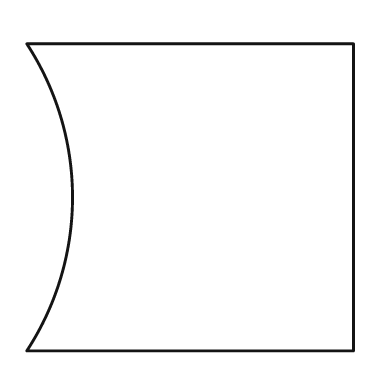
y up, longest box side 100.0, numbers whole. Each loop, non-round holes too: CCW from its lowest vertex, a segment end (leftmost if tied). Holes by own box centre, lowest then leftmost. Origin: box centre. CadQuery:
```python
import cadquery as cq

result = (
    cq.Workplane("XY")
    .moveTo(-50.0, -47.0)
    .lineTo(50.0, -47.0)
    .lineTo(50.0, 47.0)
    .lineTo(-50.0, 47.0)
    .threePointArc((-36.0, 0.0), (-50.0, -47.0))
    .close()
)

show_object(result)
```